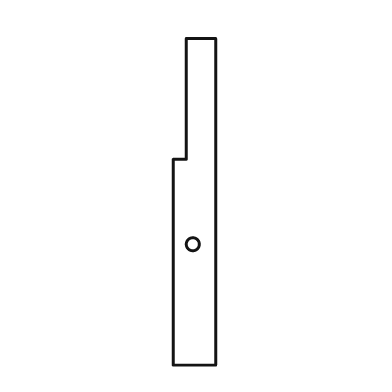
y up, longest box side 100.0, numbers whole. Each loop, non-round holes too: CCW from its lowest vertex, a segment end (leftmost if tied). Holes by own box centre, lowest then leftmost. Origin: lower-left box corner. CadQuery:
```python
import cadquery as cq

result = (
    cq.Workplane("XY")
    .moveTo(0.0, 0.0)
    .lineTo(13.0, 0.0)
    .lineTo(13.0, 100.0)
    .lineTo(4.0, 100.0)
    .lineTo(4.0, 63.0)
    .lineTo(0.0, 63.0)
    .close()
    .moveTo(6.0, 37.0)
    .circle(2.0)
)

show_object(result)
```